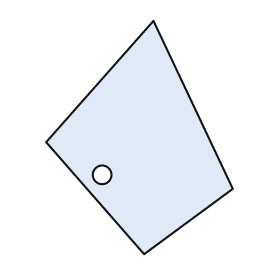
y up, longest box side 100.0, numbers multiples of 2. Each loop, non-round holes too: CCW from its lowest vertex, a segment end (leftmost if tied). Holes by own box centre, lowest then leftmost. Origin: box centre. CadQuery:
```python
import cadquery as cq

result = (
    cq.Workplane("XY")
    .moveTo(2.0, -50.0)
    .lineTo(40.0, -22.0)
    .lineTo(6.0, 50.0)
    .lineTo(-40.0, -2.0)
    .close()
    .moveTo(-16.0, -16.0)
    .circle(4.0)
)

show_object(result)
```